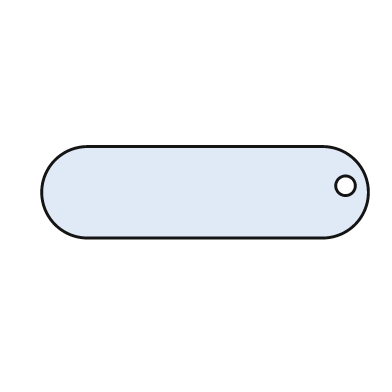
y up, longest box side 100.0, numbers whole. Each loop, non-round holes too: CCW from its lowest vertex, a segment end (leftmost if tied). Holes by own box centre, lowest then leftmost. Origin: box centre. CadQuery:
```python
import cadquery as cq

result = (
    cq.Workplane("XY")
    .moveTo(-36.0, -14.0)
    .lineTo(36.0, -14.0)
    .threePointArc((50.0, 0.0), (36.0, 14.0))
    .lineTo(-36.0, 14.0)
    .threePointArc((-50.0, 0.0), (-36.0, -14.0))
    .close()
    .moveTo(43.0, 2.0)
    .circle(3.0)
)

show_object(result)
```